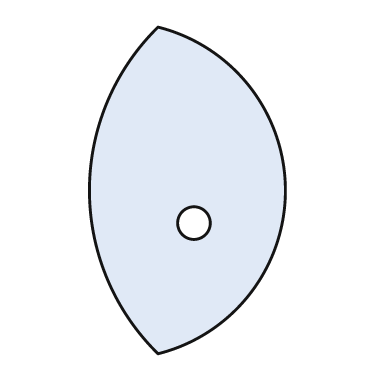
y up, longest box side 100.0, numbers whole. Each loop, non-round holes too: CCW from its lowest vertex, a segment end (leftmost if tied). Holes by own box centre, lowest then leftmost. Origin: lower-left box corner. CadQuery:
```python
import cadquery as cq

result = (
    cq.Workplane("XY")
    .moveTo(21.0, 0.0)
    .threePointArc((60.0, 50.0), (21.0, 100.0))
    .threePointArc((0.0, 50.0), (21.0, 0.0))
    .close()
    .moveTo(32.0, 40.0)
    .circle(5.0)
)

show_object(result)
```